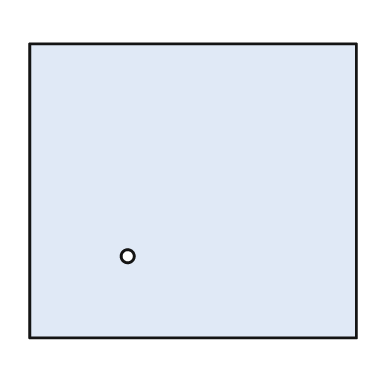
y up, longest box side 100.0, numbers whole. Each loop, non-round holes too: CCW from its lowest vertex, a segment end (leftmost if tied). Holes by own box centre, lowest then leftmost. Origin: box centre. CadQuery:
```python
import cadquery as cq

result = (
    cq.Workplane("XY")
    .moveTo(-50.0, -45.0)
    .lineTo(50.0, -45.0)
    .lineTo(50.0, 45.0)
    .lineTo(-50.0, 45.0)
    .close()
    .moveTo(-20.0, -20.0)
    .circle(2.0)
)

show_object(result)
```